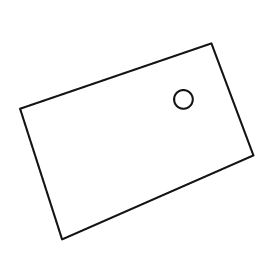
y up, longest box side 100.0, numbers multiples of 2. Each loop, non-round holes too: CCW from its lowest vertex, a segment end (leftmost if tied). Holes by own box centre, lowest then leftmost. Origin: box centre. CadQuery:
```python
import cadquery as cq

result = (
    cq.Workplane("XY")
    .moveTo(-32.0, -42.0)
    .lineTo(50.0, -6.0)
    .lineTo(32.0, 42.0)
    .lineTo(-50.0, 14.0)
    .close()
    .moveTo(20.0, 18.0)
    .circle(4.0)
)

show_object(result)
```